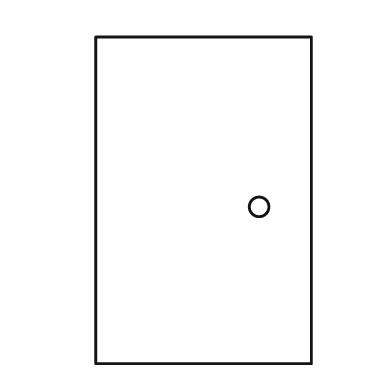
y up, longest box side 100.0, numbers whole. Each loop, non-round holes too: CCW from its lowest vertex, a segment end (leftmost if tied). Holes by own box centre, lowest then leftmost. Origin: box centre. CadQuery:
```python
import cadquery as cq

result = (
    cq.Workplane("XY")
    .moveTo(-33.0, -50.0)
    .lineTo(33.0, -50.0)
    .lineTo(33.0, 50.0)
    .lineTo(-33.0, 50.0)
    .close()
    .moveTo(17.0, -2.0)
    .circle(3.0)
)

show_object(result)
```